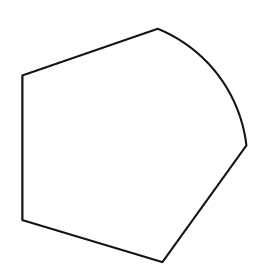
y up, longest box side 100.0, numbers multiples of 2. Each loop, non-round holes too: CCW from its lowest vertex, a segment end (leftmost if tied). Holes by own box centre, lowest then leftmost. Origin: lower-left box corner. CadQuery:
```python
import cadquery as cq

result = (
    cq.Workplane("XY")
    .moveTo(60.0, 0.0)
    .lineTo(96.0, 50.0)
    .threePointArc((84.0, 80.0), (58.0, 100.0))
    .lineTo(0.0, 80.0)
    .lineTo(0.0, 18.0)
    .close()
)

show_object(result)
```